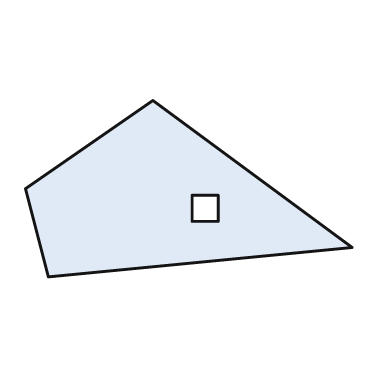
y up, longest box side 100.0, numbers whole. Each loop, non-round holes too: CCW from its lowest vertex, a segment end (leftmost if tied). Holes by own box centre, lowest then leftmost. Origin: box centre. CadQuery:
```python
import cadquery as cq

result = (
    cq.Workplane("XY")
    .moveTo(-43.0, -27.0)
    .lineTo(50.0, -18.0)
    .lineTo(-11.0, 27.0)
    .lineTo(-50.0, 0.0)
    .close()
    .moveTo(1.0, -10.0)
    .lineTo(9.0, -10.0)
    .lineTo(9.0, -2.0)
    .lineTo(1.0, -2.0)
    .close()
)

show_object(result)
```